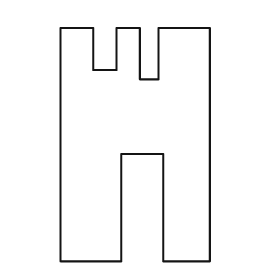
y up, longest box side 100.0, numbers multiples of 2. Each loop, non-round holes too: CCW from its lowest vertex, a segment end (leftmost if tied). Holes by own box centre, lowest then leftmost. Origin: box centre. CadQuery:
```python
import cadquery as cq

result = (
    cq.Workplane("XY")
    .moveTo(-32.0, -50.0)
    .lineTo(-6.0, -50.0)
    .lineTo(-6.0, -4.0)
    .lineTo(12.0, -4.0)
    .lineTo(12.0, -50.0)
    .lineTo(32.0, -50.0)
    .lineTo(32.0, 50.0)
    .lineTo(10.0, 50.0)
    .lineTo(10.0, 28.0)
    .lineTo(2.0, 28.0)
    .lineTo(2.0, 50.0)
    .lineTo(-8.0, 50.0)
    .lineTo(-8.0, 32.0)
    .lineTo(-18.0, 32.0)
    .lineTo(-18.0, 50.0)
    .lineTo(-32.0, 50.0)
    .close()
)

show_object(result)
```